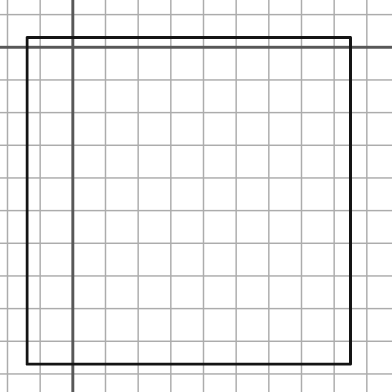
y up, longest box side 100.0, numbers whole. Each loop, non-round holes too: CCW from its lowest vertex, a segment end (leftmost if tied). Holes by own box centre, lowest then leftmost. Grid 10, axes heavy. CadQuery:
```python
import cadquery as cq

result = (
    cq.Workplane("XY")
    .moveTo(-14.0, -97.0)
    .lineTo(85.0, -97.0)
    .lineTo(85.0, 3.0)
    .lineTo(-14.0, 3.0)
    .close()
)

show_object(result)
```